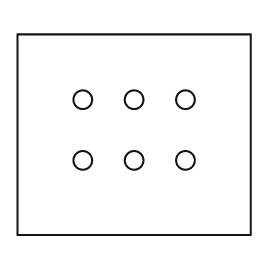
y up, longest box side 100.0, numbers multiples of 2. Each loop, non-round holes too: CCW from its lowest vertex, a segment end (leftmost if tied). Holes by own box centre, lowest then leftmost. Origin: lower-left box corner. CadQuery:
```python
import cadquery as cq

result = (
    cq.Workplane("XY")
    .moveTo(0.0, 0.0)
    .lineTo(100.0, 0.0)
    .lineTo(100.0, 86.0)
    .lineTo(0.0, 86.0)
    .close()
    .moveTo(28.0, 32.0)
    .circle(4.0)
    .moveTo(50.0, 32.0)
    .circle(4.0)
    .moveTo(72.0, 32.0)
    .circle(4.0)
    .moveTo(28.0, 58.0)
    .circle(4.0)
    .moveTo(50.0, 58.0)
    .circle(4.0)
    .moveTo(72.0, 58.0)
    .circle(4.0)
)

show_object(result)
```